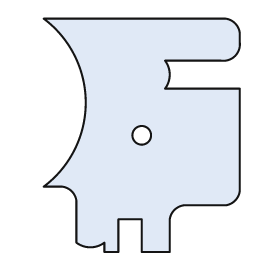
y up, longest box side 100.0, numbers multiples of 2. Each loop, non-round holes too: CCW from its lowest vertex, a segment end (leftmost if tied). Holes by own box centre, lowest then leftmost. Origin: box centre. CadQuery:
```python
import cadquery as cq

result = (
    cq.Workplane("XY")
    .moveTo(-16.0, -50.0)
    .lineTo(-10.0, -50.0)
    .lineTo(-10.0, -36.0)
    .lineTo(0.0, -36.0)
    .lineTo(0.0, -50.0)
    .lineTo(12.0, -50.0)
    .lineTo(12.0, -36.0)
    .threePointArc((14.0, -32.0), (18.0, -30.0))
    .lineTo(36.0, -30.0)
    .threePointArc((40.0, -28.0), (42.0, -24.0))
    .lineTo(42.0, 20.0)
    .lineTo(10.0, 20.0)
    .threePointArc((12.0, 26.0), (10.0, 32.0))
    .lineTo(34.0, 32.0)
    .threePointArc((40.0, 34.0), (42.0, 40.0))
    .lineTo(42.0, 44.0)
    .threePointArc((40.0, 48.0), (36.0, 50.0))
    .lineTo(-42.0, 50.0)
    .threePointArc((-24.0, 14.0), (-42.0, -22.0))
    .lineTo(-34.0, -22.0)
    .threePointArc((-30.0, -24.0), (-28.0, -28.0))
    .lineTo(-28.0, -46.0)
    .threePointArc((-22.0, -48.0), (-16.0, -46.0))
    .close()
    .moveTo(0.0, 0.0)
    .circle(4.0)
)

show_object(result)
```